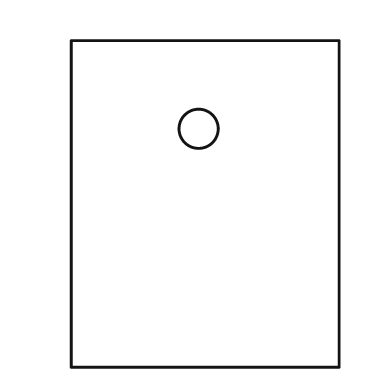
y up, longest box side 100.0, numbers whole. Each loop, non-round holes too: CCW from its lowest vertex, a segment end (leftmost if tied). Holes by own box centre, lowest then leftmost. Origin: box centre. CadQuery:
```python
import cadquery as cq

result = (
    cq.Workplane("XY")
    .moveTo(-41.0, -50.0)
    .lineTo(41.0, -50.0)
    .lineTo(41.0, 50.0)
    .lineTo(-41.0, 50.0)
    .close()
    .moveTo(-2.0, 23.0)
    .circle(6.0)
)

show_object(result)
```